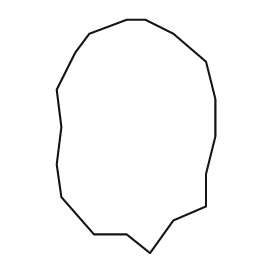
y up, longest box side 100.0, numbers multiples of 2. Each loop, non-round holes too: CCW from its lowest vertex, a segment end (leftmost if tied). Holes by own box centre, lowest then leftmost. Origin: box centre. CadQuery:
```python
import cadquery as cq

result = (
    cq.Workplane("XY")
    .moveTo(6.0, -50.0)
    .lineTo(16.0, -36.0)
    .lineTo(30.0, -30.0)
    .lineTo(30.0, -16.0)
    .lineTo(34.0, 0.0)
    .lineTo(34.0, 16.0)
    .lineTo(30.0, 32.0)
    .lineTo(16.0, 44.0)
    .lineTo(4.0, 50.0)
    .lineTo(-4.0, 50.0)
    .lineTo(-20.0, 44.0)
    .lineTo(-26.0, 36.0)
    .lineTo(-34.0, 20.0)
    .lineTo(-32.0, 4.0)
    .lineTo(-34.0, -12.0)
    .lineTo(-32.0, -26.0)
    .lineTo(-18.0, -42.0)
    .lineTo(-4.0, -42.0)
    .close()
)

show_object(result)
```